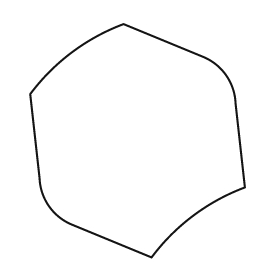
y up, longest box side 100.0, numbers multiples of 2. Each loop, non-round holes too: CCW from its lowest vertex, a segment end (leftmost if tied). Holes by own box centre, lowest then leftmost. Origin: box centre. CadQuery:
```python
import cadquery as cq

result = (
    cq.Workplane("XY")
    .moveTo(6.0, -50.0)
    .threePointArc((24.0, -32.0), (46.0, -20.0))
    .lineTo(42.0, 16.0)
    .threePointArc((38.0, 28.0), (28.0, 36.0))
    .lineTo(-6.0, 50.0)
    .threePointArc((-28.0, 38.0), (-46.0, 20.0))
    .lineTo(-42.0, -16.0)
    .threePointArc((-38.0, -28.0), (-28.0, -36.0))
    .close()
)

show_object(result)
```